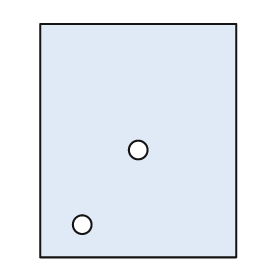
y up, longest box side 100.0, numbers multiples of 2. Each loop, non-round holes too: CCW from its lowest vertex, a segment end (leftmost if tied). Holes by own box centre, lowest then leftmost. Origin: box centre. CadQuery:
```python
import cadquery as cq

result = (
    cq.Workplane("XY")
    .moveTo(-42.0, -50.0)
    .lineTo(42.0, -50.0)
    .lineTo(42.0, 50.0)
    .lineTo(-42.0, 50.0)
    .close()
    .moveTo(-24.0, -36.0)
    .circle(4.0)
    .moveTo(0.0, -4.0)
    .circle(4.0)
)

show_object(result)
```